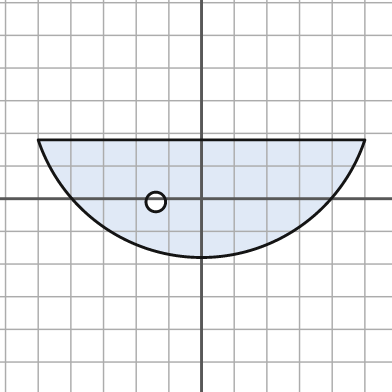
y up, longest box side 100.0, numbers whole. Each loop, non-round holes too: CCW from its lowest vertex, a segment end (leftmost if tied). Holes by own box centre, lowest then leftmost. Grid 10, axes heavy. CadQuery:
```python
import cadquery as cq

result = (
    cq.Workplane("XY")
    .moveTo(-50.0, 18.0)
    .threePointArc((0.0, -18.0), (50.0, 18.0))
    .close()
    .moveTo(-14.0, -1.0)
    .circle(3.0)
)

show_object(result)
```